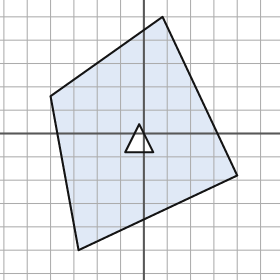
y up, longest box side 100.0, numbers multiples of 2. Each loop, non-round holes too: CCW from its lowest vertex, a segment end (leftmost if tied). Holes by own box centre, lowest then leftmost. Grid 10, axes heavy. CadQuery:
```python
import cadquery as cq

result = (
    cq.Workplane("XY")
    .moveTo(-28.0, -50.0)
    .lineTo(40.0, -18.0)
    .lineTo(8.0, 50.0)
    .lineTo(-40.0, 16.0)
    .close()
    .moveTo(-8.0, -8.0)
    .lineTo(4.0, -8.0)
    .lineTo(-2.0, 4.0)
    .close()
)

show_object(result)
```